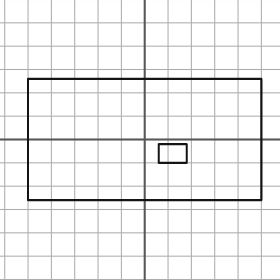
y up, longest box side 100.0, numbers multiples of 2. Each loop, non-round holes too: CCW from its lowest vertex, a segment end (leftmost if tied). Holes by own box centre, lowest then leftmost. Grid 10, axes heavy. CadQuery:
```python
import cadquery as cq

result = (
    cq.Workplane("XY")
    .moveTo(-50.0, -26.0)
    .lineTo(50.0, -26.0)
    .lineTo(50.0, 26.0)
    .lineTo(-50.0, 26.0)
    .close()
    .moveTo(6.0, -10.0)
    .lineTo(18.0, -10.0)
    .lineTo(18.0, -2.0)
    .lineTo(6.0, -2.0)
    .close()
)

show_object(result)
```